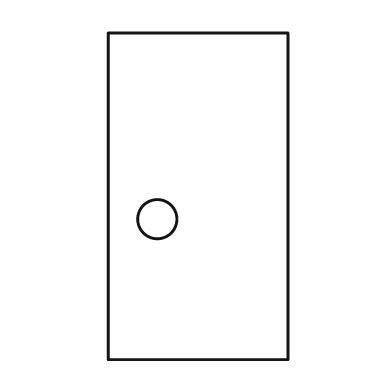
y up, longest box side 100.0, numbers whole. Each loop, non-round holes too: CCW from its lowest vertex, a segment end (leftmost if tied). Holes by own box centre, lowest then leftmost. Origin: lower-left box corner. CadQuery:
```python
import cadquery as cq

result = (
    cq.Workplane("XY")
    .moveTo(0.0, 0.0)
    .lineTo(55.0, 0.0)
    .lineTo(55.0, 100.0)
    .lineTo(0.0, 100.0)
    .close()
    .moveTo(15.0, 43.0)
    .circle(6.0)
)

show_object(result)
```